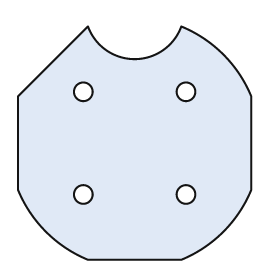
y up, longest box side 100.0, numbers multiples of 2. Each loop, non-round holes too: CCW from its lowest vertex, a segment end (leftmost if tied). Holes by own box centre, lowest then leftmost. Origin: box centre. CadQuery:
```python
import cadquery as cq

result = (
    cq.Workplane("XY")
    .moveTo(-20.0, -50.0)
    .lineTo(20.0, -50.0)
    .threePointArc((38.0, -38.0), (50.0, -20.0))
    .lineTo(50.0, 20.0)
    .threePointArc((38.0, 38.0), (20.0, 50.0))
    .threePointArc((0.0, 36.0), (-20.0, 50.0))
    .lineTo(-50.0, 20.0)
    .lineTo(-50.0, -20.0)
    .threePointArc((-38.0, -38.0), (-20.0, -50.0))
    .close()
    .moveTo(-22.0, -22.0)
    .circle(4.0)
    .moveTo(22.0, -22.0)
    .circle(4.0)
    .moveTo(-22.0, 22.0)
    .circle(4.0)
    .moveTo(22.0, 22.0)
    .circle(4.0)
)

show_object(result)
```